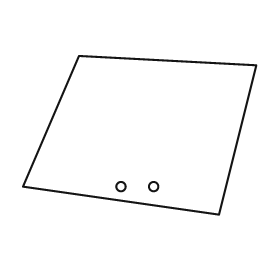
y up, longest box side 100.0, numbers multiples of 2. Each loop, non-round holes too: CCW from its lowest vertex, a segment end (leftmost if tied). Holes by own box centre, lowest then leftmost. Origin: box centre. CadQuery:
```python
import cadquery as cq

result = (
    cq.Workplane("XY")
    .moveTo(34.0, -34.0)
    .lineTo(50.0, 30.0)
    .lineTo(-26.0, 34.0)
    .lineTo(-50.0, -22.0)
    .close()
    .moveTo(-8.0, -22.0)
    .circle(2.0)
    .moveTo(6.0, -22.0)
    .circle(2.0)
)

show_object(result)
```